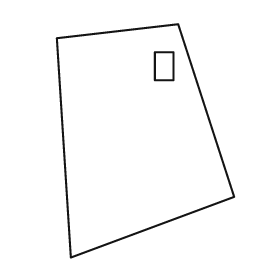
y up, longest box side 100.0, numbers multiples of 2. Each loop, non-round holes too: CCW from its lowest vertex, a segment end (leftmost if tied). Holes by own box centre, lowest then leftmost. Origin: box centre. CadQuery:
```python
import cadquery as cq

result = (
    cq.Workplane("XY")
    .moveTo(-32.0, -50.0)
    .lineTo(38.0, -24.0)
    .lineTo(14.0, 50.0)
    .lineTo(-38.0, 44.0)
    .close()
    .moveTo(4.0, 26.0)
    .lineTo(12.0, 26.0)
    .lineTo(12.0, 38.0)
    .lineTo(4.0, 38.0)
    .close()
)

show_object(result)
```